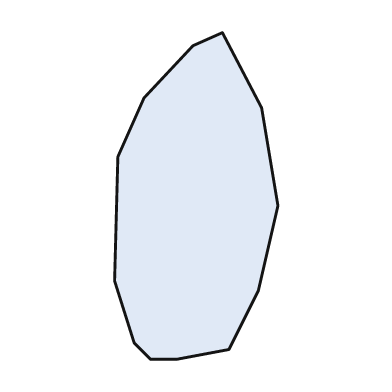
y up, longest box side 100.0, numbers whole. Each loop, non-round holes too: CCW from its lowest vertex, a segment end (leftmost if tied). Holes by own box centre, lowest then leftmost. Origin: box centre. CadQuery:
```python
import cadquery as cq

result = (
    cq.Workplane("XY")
    .moveTo(-14.0, -50.0)
    .lineTo(-6.0, -50.0)
    .lineTo(10.0, -47.0)
    .lineTo(19.0, -29.0)
    .lineTo(25.0, -3.0)
    .lineTo(20.0, 27.0)
    .lineTo(8.0, 50.0)
    .lineTo(-1.0, 46.0)
    .lineTo(-16.0, 30.0)
    .lineTo(-24.0, 12.0)
    .lineTo(-25.0, -26.0)
    .lineTo(-19.0, -45.0)
    .close()
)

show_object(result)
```